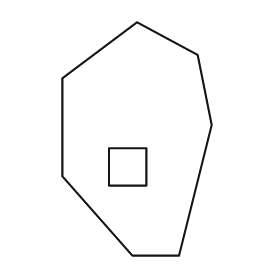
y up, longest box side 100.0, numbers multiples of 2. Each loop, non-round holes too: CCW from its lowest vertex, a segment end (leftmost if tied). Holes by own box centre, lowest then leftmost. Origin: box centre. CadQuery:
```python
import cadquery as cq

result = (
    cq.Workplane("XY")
    .moveTo(-2.0, -50.0)
    .lineTo(18.0, -50.0)
    .lineTo(32.0, 6.0)
    .lineTo(26.0, 36.0)
    .lineTo(0.0, 50.0)
    .lineTo(-32.0, 26.0)
    .lineTo(-32.0, -16.0)
    .close()
    .moveTo(-12.0, -20.0)
    .lineTo(4.0, -20.0)
    .lineTo(4.0, -4.0)
    .lineTo(-12.0, -4.0)
    .close()
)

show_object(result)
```